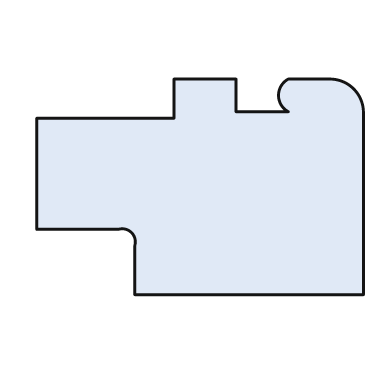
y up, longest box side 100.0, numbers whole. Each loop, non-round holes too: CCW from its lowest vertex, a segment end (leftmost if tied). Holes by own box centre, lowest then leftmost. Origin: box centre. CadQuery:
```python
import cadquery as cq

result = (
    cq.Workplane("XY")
    .moveTo(-20.0, -33.0)
    .lineTo(50.0, -33.0)
    .lineTo(50.0, 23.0)
    .threePointArc((47.0, 30.0), (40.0, 33.0))
    .lineTo(27.0, 33.0)
    .threePointArc((24.0, 28.0), (27.0, 23.0))
    .lineTo(11.0, 23.0)
    .lineTo(11.0, 33.0)
    .lineTo(-8.0, 33.0)
    .lineTo(-8.0, 21.0)
    .lineTo(-50.0, 21.0)
    .lineTo(-50.0, -13.0)
    .lineTo(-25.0, -13.0)
    .threePointArc((-21.0, -14.0), (-20.0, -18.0))
    .close()
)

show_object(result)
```